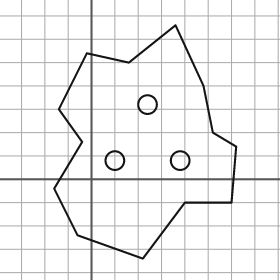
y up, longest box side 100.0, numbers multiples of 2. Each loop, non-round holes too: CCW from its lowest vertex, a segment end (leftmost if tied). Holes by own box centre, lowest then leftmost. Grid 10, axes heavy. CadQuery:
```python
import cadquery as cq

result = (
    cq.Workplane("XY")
    .moveTo(22.0, -34.0)
    .lineTo(40.0, -10.0)
    .lineTo(60.0, -10.0)
    .lineTo(62.0, 14.0)
    .lineTo(52.0, 20.0)
    .lineTo(48.0, 40.0)
    .lineTo(36.0, 66.0)
    .lineTo(16.0, 50.0)
    .lineTo(-2.0, 54.0)
    .lineTo(-14.0, 30.0)
    .lineTo(-4.0, 16.0)
    .lineTo(-16.0, -4.0)
    .lineTo(-6.0, -24.0)
    .close()
    .moveTo(10.0, 8.0)
    .circle(4.0)
    .moveTo(38.0, 8.0)
    .circle(4.0)
    .moveTo(24.0, 32.0)
    .circle(4.0)
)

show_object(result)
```